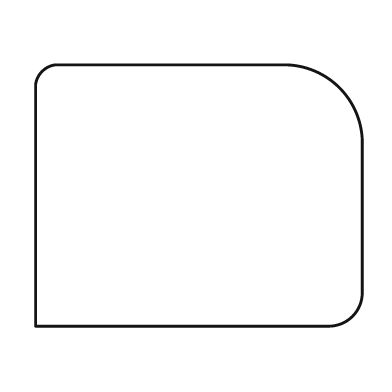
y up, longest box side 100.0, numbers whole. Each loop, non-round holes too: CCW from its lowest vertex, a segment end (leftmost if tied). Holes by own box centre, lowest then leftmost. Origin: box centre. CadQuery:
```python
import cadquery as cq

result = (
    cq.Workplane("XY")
    .moveTo(-50.0, -40.0)
    .lineTo(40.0, -40.0)
    .threePointArc((47.0, -37.0), (50.0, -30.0))
    .lineTo(50.0, 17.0)
    .threePointArc((43.0, 33.0), (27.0, 40.0))
    .lineTo(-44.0, 40.0)
    .threePointArc((-48.0, 38.0), (-50.0, 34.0))
    .close()
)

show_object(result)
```